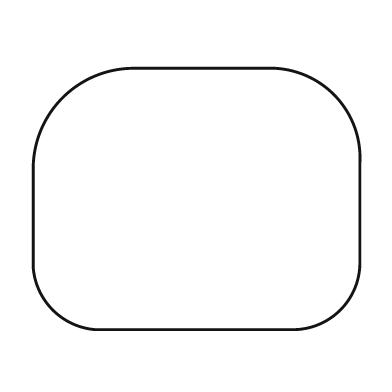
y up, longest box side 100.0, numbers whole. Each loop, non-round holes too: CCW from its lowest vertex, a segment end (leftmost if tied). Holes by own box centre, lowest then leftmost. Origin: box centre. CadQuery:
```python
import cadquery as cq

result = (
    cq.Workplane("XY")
    .moveTo(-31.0, -40.0)
    .lineTo(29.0, -40.0)
    .threePointArc((44.0, -34.0), (50.0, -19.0))
    .lineTo(50.0, 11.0)
    .threePointArc((42.0, 32.0), (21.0, 40.0))
    .lineTo(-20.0, 40.0)
    .threePointArc((-41.0, 31.0), (-50.0, 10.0))
    .lineTo(-50.0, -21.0)
    .threePointArc((-44.0, -34.0), (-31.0, -40.0))
    .close()
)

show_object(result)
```